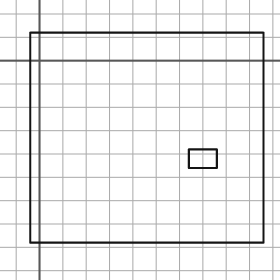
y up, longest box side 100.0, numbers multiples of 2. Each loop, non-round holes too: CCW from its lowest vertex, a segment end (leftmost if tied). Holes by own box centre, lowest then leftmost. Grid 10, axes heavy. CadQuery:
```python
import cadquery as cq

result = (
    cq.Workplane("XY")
    .moveTo(-4.0, -78.0)
    .lineTo(96.0, -78.0)
    .lineTo(96.0, 12.0)
    .lineTo(-4.0, 12.0)
    .close()
    .moveTo(64.0, -46.0)
    .lineTo(76.0, -46.0)
    .lineTo(76.0, -38.0)
    .lineTo(64.0, -38.0)
    .close()
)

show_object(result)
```